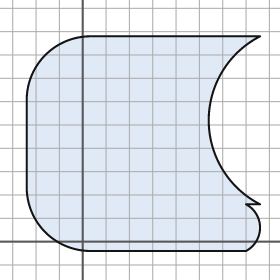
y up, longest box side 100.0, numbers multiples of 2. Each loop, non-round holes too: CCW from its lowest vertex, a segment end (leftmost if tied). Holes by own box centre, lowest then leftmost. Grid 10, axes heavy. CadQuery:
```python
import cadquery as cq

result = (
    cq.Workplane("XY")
    .moveTo(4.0, -4.0)
    .lineTo(70.0, -4.0)
    .threePointArc((76.0, 6.0), (70.0, 16.0))
    .lineTo(76.0, 16.0)
    .threePointArc((54.0, 52.0), (76.0, 88.0))
    .lineTo(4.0, 88.0)
    .threePointArc((-16.0, 80.0), (-24.0, 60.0))
    .lineTo(-24.0, 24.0)
    .threePointArc((-16.0, 4.0), (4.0, -4.0))
    .close()
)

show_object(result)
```